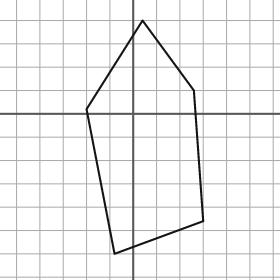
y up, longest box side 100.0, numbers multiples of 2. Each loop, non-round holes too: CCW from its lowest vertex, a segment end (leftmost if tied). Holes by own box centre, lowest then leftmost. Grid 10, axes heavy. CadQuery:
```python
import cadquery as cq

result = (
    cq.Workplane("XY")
    .moveTo(-8.0, -60.0)
    .lineTo(30.0, -46.0)
    .lineTo(26.0, 10.0)
    .lineTo(4.0, 40.0)
    .lineTo(-20.0, 2.0)
    .close()
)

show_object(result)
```